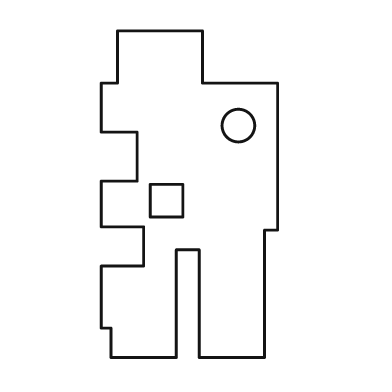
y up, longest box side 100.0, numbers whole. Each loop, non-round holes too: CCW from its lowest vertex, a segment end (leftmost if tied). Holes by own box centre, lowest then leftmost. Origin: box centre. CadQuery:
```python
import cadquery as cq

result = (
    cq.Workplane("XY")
    .moveTo(-24.0, -50.0)
    .lineTo(-4.0, -50.0)
    .lineTo(-4.0, -17.0)
    .lineTo(3.0, -17.0)
    .lineTo(3.0, -50.0)
    .lineTo(23.0, -50.0)
    .lineTo(23.0, -11.0)
    .lineTo(27.0, -11.0)
    .lineTo(27.0, 34.0)
    .lineTo(4.0, 34.0)
    .lineTo(4.0, 50.0)
    .lineTo(-22.0, 50.0)
    .lineTo(-22.0, 34.0)
    .lineTo(-27.0, 34.0)
    .lineTo(-27.0, 19.0)
    .lineTo(-16.0, 19.0)
    .lineTo(-16.0, 4.0)
    .lineTo(-27.0, 4.0)
    .lineTo(-27.0, -10.0)
    .lineTo(-14.0, -10.0)
    .lineTo(-14.0, -22.0)
    .lineTo(-27.0, -22.0)
    .lineTo(-27.0, -41.0)
    .lineTo(-24.0, -41.0)
    .close()
    .moveTo(-12.0, -7.0)
    .lineTo(-2.0, -7.0)
    .lineTo(-2.0, 3.0)
    .lineTo(-12.0, 3.0)
    .close()
    .moveTo(15.0, 21.0)
    .circle(5.0)
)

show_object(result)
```